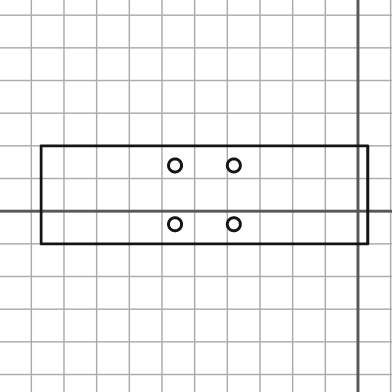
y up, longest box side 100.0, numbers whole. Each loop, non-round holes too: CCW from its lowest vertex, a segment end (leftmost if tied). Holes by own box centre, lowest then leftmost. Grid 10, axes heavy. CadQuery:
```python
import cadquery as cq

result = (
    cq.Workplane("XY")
    .moveTo(-97.0, -10.0)
    .lineTo(3.0, -10.0)
    .lineTo(3.0, 20.0)
    .lineTo(-97.0, 20.0)
    .close()
    .moveTo(-56.0, -4.0)
    .circle(2.0)
    .moveTo(-38.0, -4.0)
    .circle(2.0)
    .moveTo(-56.0, 14.0)
    .circle(2.0)
    .moveTo(-38.0, 14.0)
    .circle(2.0)
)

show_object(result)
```